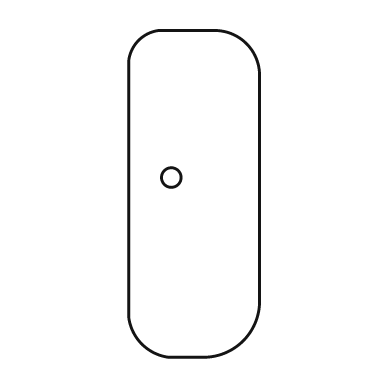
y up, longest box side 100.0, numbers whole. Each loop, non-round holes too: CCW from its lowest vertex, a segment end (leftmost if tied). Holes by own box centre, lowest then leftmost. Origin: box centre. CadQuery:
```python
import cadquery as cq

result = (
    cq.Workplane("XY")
    .moveTo(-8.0, -50.0)
    .lineTo(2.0, -50.0)
    .threePointArc((15.0, -45.0), (20.0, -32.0))
    .lineTo(20.0, 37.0)
    .threePointArc((16.0, 46.0), (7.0, 50.0))
    .lineTo(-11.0, 50.0)
    .threePointArc((-17.0, 47.0), (-20.0, 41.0))
    .lineTo(-20.0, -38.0)
    .threePointArc((-16.0, -46.0), (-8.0, -50.0))
    .close()
    .moveTo(-7.0, 5.0)
    .circle(3.0)
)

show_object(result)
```